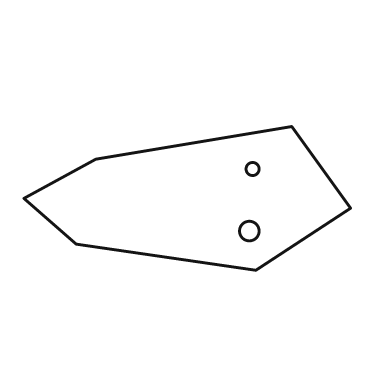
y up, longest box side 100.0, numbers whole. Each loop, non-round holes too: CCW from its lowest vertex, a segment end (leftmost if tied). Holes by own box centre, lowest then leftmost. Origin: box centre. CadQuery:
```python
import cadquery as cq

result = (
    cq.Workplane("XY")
    .moveTo(21.0, -22.0)
    .lineTo(50.0, -3.0)
    .lineTo(32.0, 22.0)
    .lineTo(-28.0, 12.0)
    .lineTo(-50.0, 0.0)
    .lineTo(-34.0, -14.0)
    .close()
    .moveTo(19.0, -10.0)
    .circle(3.0)
    .moveTo(20.0, 9.0)
    .circle(2.0)
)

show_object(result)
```